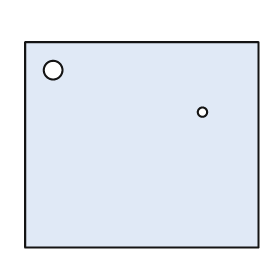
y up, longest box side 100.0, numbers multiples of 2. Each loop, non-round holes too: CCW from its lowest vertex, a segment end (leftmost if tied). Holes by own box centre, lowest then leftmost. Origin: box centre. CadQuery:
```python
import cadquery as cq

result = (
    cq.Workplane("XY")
    .moveTo(-50.0, -44.0)
    .lineTo(50.0, -44.0)
    .lineTo(50.0, 44.0)
    .lineTo(-50.0, 44.0)
    .close()
    .moveTo(26.0, 14.0)
    .circle(2.0)
    .moveTo(-38.0, 32.0)
    .circle(4.0)
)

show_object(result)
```